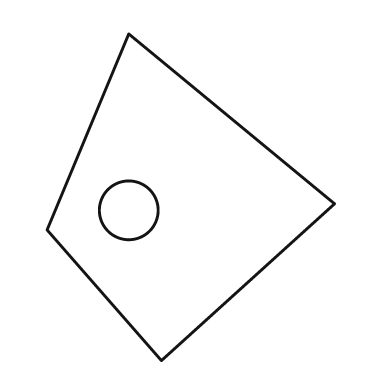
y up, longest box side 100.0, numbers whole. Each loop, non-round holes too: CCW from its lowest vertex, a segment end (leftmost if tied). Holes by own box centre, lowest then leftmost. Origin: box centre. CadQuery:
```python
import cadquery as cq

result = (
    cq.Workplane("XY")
    .moveTo(-9.0, -50.0)
    .lineTo(44.0, -2.0)
    .lineTo(-19.0, 50.0)
    .lineTo(-44.0, -10.0)
    .close()
    .moveTo(-19.0, -4.0)
    .circle(9.0)
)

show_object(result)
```